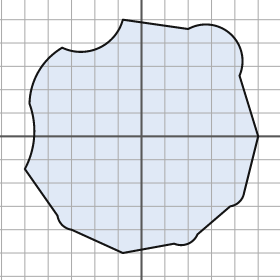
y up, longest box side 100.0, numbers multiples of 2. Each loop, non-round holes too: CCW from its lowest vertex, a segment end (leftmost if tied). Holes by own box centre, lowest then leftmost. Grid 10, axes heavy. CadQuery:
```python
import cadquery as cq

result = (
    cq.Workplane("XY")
    .moveTo(-8.0, -50.0)
    .lineTo(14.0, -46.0)
    .threePointArc((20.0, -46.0), (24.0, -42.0))
    .lineTo(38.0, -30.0)
    .threePointArc((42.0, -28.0), (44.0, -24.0))
    .lineTo(50.0, 0.0)
    .lineTo(42.0, 26.0)
    .threePointArc((38.0, 44.0), (20.0, 46.0))
    .lineTo(-8.0, 50.0)
    .threePointArc((-18.0, 38.0), (-34.0, 38.0))
    .threePointArc((-44.0, 28.0), (-48.0, 14.0))
    .threePointArc((-46.0, 0.0), (-50.0, -14.0))
    .lineTo(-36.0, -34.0)
    .threePointArc((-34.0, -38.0), (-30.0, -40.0))
    .close()
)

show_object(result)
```